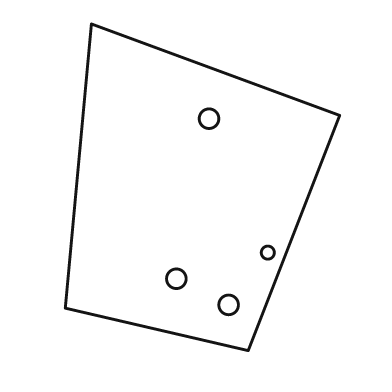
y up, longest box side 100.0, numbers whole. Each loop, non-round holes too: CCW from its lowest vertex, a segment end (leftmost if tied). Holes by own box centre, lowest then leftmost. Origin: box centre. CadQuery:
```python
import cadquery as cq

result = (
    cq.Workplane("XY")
    .moveTo(14.0, -50.0)
    .lineTo(42.0, 22.0)
    .lineTo(-34.0, 50.0)
    .lineTo(-42.0, -37.0)
    .close()
    .moveTo(8.0, -36.0)
    .circle(3.0)
    .moveTo(-8.0, -28.0)
    .circle(3.0)
    .moveTo(20.0, -20.0)
    .circle(2.0)
    .moveTo(2.0, 21.0)
    .circle(3.0)
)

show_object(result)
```